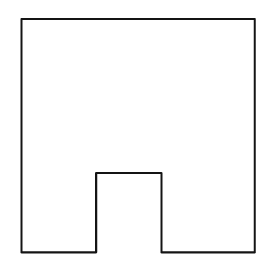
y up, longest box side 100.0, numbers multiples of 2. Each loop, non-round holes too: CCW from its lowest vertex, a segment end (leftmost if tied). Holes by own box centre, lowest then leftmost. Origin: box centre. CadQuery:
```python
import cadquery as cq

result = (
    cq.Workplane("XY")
    .moveTo(-50.0, -50.0)
    .lineTo(-18.0, -50.0)
    .lineTo(-18.0, -16.0)
    .lineTo(10.0, -16.0)
    .lineTo(10.0, -50.0)
    .lineTo(50.0, -50.0)
    .lineTo(50.0, 50.0)
    .lineTo(-50.0, 50.0)
    .close()
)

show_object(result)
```